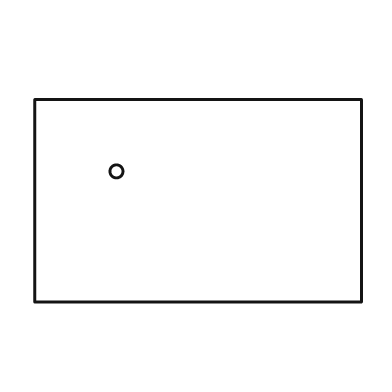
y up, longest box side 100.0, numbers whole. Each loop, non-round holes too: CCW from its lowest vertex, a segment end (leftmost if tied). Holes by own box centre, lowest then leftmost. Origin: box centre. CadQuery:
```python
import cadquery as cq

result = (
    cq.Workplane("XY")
    .moveTo(-50.0, -31.0)
    .lineTo(50.0, -31.0)
    .lineTo(50.0, 31.0)
    .lineTo(-50.0, 31.0)
    .close()
    .moveTo(-25.0, 9.0)
    .circle(2.0)
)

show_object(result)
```